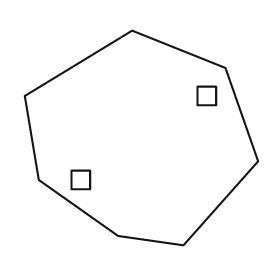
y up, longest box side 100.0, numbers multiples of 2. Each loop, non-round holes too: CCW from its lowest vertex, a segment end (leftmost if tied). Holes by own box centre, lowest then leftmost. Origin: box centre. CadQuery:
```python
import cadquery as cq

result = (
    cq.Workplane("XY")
    .moveTo(18.0, -46.0)
    .lineTo(50.0, -10.0)
    .lineTo(36.0, 30.0)
    .lineTo(-4.0, 46.0)
    .lineTo(-50.0, 18.0)
    .lineTo(-44.0, -18.0)
    .lineTo(-10.0, -42.0)
    .close()
    .moveTo(-30.0, -22.0)
    .lineTo(-22.0, -22.0)
    .lineTo(-22.0, -14.0)
    .lineTo(-30.0, -14.0)
    .close()
    .moveTo(24.0, 14.0)
    .lineTo(32.0, 14.0)
    .lineTo(32.0, 22.0)
    .lineTo(24.0, 22.0)
    .close()
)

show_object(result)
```